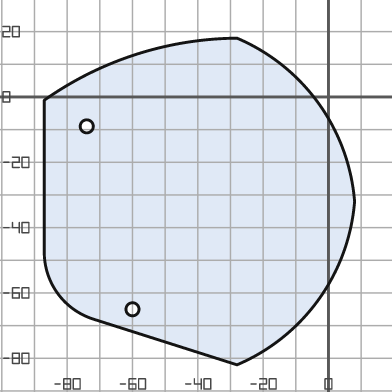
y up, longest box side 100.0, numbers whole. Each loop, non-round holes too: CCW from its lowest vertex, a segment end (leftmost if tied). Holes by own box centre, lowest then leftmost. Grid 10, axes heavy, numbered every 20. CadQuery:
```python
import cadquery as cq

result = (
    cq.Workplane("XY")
    .moveTo(-28.0, -82.0)
    .threePointArc((-3.0, -62.0), (8.0, -32.0))
    .threePointArc((-3.0, -2.0), (-28.0, 18.0))
    .threePointArc((-59.0, 13.0), (-87.0, -1.0))
    .lineTo(-87.0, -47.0)
    .threePointArc((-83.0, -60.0), (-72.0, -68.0))
    .close()
    .moveTo(-60.0, -65.0)
    .circle(2.0)
    .moveTo(-74.0, -9.0)
    .circle(2.0)
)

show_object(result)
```